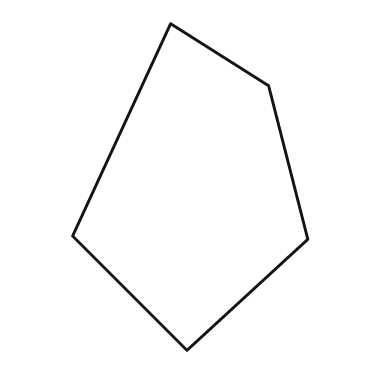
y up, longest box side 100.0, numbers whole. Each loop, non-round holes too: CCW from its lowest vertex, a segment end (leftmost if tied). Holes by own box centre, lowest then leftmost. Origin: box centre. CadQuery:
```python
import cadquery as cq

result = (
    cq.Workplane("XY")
    .moveTo(-1.0, -50.0)
    .lineTo(36.0, -16.0)
    .lineTo(24.0, 31.0)
    .lineTo(-6.0, 50.0)
    .lineTo(-36.0, -15.0)
    .close()
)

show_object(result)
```